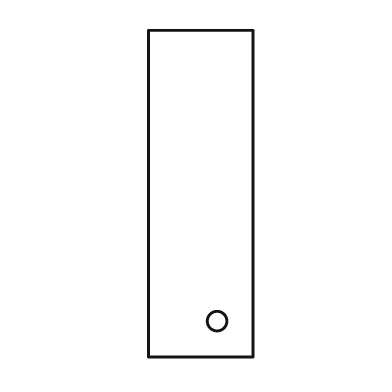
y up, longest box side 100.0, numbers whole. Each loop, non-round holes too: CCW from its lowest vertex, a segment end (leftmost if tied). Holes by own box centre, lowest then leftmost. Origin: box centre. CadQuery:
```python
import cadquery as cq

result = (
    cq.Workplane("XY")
    .moveTo(-16.0, -50.0)
    .lineTo(16.0, -50.0)
    .lineTo(16.0, 50.0)
    .lineTo(-16.0, 50.0)
    .close()
    .moveTo(5.0, -39.0)
    .circle(3.0)
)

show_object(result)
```